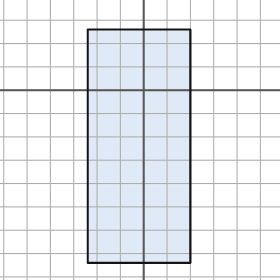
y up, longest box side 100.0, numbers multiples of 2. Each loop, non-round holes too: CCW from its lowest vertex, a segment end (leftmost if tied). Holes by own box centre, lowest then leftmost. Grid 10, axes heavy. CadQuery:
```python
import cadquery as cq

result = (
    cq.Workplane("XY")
    .moveTo(-24.0, -74.0)
    .lineTo(20.0, -74.0)
    .lineTo(20.0, 26.0)
    .lineTo(-24.0, 26.0)
    .close()
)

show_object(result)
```